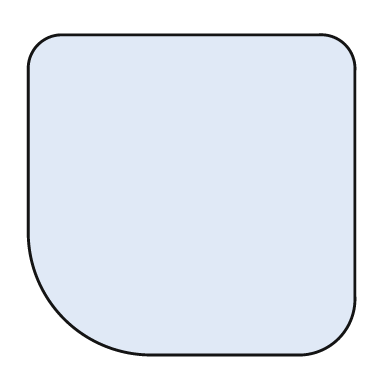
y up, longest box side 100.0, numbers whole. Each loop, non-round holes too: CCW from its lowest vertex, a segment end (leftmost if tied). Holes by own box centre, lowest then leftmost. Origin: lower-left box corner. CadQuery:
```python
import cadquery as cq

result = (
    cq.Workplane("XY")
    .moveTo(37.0, 0.0)
    .lineTo(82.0, 0.0)
    .threePointArc((95.0, 5.0), (100.0, 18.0))
    .lineTo(100.0, 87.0)
    .threePointArc((97.0, 95.0), (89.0, 98.0))
    .lineTo(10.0, 98.0)
    .threePointArc((3.0, 95.0), (0.0, 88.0))
    .lineTo(0.0, 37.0)
    .threePointArc((11.0, 11.0), (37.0, 0.0))
    .close()
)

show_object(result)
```